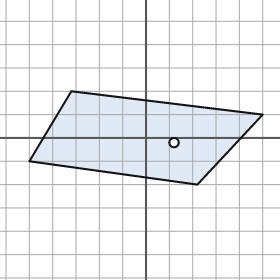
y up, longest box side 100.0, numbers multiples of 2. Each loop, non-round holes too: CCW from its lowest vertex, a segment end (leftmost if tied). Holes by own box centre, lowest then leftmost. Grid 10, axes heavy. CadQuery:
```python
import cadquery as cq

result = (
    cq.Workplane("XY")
    .moveTo(22.0, -20.0)
    .lineTo(50.0, 10.0)
    .lineTo(-32.0, 20.0)
    .lineTo(-50.0, -10.0)
    .close()
    .moveTo(12.0, -2.0)
    .circle(2.0)
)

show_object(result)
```